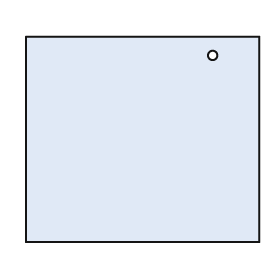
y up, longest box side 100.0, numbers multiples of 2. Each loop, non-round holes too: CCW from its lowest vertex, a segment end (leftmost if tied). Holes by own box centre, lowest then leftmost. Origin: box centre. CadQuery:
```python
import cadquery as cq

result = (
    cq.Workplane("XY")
    .moveTo(-50.0, -44.0)
    .lineTo(50.0, -44.0)
    .lineTo(50.0, 44.0)
    .lineTo(-50.0, 44.0)
    .close()
    .moveTo(30.0, 36.0)
    .circle(2.0)
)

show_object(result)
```